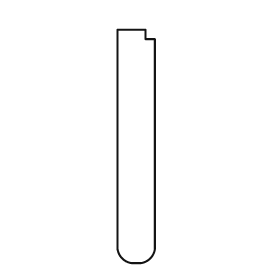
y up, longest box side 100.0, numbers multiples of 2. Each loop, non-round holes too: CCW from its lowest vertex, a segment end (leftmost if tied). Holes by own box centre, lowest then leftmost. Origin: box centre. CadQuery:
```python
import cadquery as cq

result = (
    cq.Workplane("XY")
    .moveTo(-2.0, -50.0)
    .lineTo(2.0, -50.0)
    .threePointArc((6.0, -48.0), (8.0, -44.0))
    .lineTo(8.0, 46.0)
    .lineTo(4.0, 46.0)
    .lineTo(4.0, 50.0)
    .lineTo(-8.0, 50.0)
    .lineTo(-8.0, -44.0)
    .threePointArc((-6.0, -48.0), (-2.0, -50.0))
    .close()
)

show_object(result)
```